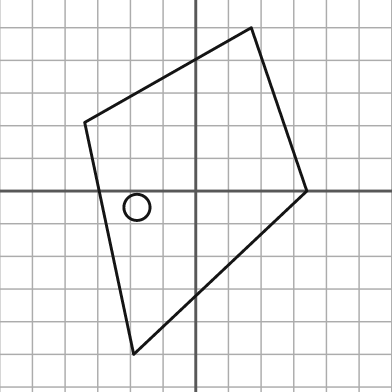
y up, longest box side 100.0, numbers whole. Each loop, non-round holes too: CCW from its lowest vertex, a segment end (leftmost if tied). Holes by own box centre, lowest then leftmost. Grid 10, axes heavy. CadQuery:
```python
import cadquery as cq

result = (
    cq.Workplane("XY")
    .moveTo(-19.0, -50.0)
    .lineTo(34.0, 0.0)
    .lineTo(17.0, 50.0)
    .lineTo(-34.0, 21.0)
    .close()
    .moveTo(-18.0, -5.0)
    .circle(4.0)
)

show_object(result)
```